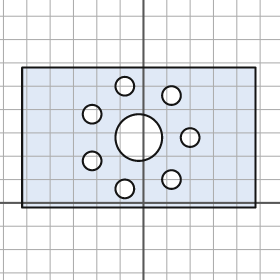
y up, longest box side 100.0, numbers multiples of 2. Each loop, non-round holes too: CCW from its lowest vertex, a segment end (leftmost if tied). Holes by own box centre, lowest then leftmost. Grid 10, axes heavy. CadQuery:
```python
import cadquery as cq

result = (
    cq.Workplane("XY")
    .moveTo(-52.0, -2.0)
    .lineTo(48.0, -2.0)
    .lineTo(48.0, 58.0)
    .lineTo(-52.0, 58.0)
    .close()
    .moveTo(-8.0, 6.0)
    .circle(4.0)
    .moveTo(12.0, 10.0)
    .circle(4.0)
    .moveTo(-22.0, 18.0)
    .circle(4.0)
    .moveTo(-2.0, 28.0)
    .circle(10.0)
    .moveTo(20.0, 28.0)
    .circle(4.0)
    .moveTo(-22.0, 38.0)
    .circle(4.0)
    .moveTo(12.0, 46.0)
    .circle(4.0)
    .moveTo(-8.0, 50.0)
    .circle(4.0)
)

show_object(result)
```